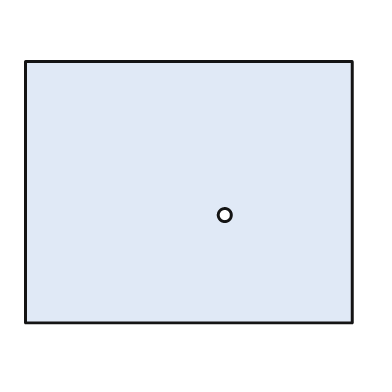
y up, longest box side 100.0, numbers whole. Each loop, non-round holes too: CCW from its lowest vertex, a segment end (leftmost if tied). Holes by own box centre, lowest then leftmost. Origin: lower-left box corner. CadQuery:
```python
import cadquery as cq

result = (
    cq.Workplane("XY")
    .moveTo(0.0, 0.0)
    .lineTo(100.0, 0.0)
    .lineTo(100.0, 80.0)
    .lineTo(0.0, 80.0)
    .close()
    .moveTo(61.0, 33.0)
    .circle(2.0)
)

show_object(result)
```